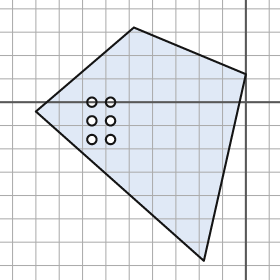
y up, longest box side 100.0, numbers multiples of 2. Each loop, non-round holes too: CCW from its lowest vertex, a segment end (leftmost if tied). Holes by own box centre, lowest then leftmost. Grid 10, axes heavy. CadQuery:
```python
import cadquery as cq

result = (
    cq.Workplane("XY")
    .moveTo(-18.0, -68.0)
    .lineTo(0.0, 12.0)
    .lineTo(-48.0, 32.0)
    .lineTo(-90.0, -4.0)
    .close()
    .moveTo(-66.0, -16.0)
    .circle(2.0)
    .moveTo(-58.0, -16.0)
    .circle(2.0)
    .moveTo(-66.0, -8.0)
    .circle(2.0)
    .moveTo(-58.0, -8.0)
    .circle(2.0)
    .moveTo(-66.0, 0.0)
    .circle(2.0)
    .moveTo(-58.0, 0.0)
    .circle(2.0)
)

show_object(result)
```